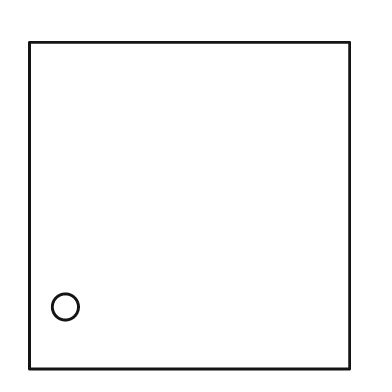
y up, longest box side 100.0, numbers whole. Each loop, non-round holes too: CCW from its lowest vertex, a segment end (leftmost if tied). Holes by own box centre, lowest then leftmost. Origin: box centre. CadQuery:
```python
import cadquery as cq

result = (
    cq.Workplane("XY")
    .moveTo(-49.0, -50.0)
    .lineTo(49.0, -50.0)
    .lineTo(49.0, 50.0)
    .lineTo(-49.0, 50.0)
    .close()
    .moveTo(-38.0, -31.0)
    .circle(4.0)
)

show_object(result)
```